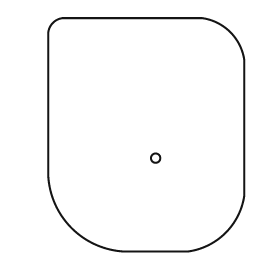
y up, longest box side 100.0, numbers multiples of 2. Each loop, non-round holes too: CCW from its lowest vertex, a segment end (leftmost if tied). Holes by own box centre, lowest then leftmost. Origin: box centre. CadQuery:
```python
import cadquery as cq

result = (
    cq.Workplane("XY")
    .moveTo(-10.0, -50.0)
    .lineTo(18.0, -50.0)
    .threePointArc((34.0, -42.0), (42.0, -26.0))
    .lineTo(42.0, 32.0)
    .threePointArc((36.0, 44.0), (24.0, 50.0))
    .lineTo(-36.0, 50.0)
    .threePointArc((-40.0, 48.0), (-42.0, 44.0))
    .lineTo(-42.0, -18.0)
    .threePointArc((-32.0, -40.0), (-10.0, -50.0))
    .close()
    .moveTo(4.0, -10.0)
    .circle(2.0)
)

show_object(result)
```